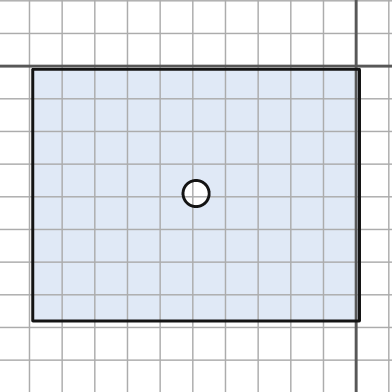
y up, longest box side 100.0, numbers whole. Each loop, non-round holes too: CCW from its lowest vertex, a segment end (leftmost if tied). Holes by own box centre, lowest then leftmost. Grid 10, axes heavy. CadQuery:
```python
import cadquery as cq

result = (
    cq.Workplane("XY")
    .moveTo(-99.0, -78.0)
    .lineTo(1.0, -78.0)
    .lineTo(1.0, -1.0)
    .lineTo(-99.0, -1.0)
    .close()
    .moveTo(-49.0, -39.0)
    .circle(4.0)
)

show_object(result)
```